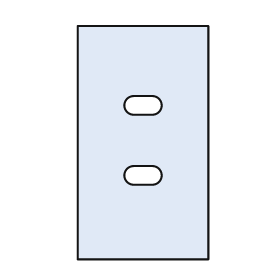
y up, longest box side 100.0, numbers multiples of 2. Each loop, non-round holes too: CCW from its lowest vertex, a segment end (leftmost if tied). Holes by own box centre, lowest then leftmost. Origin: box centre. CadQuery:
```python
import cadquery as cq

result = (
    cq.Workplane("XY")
    .moveTo(-28.0, -50.0)
    .lineTo(28.0, -50.0)
    .lineTo(28.0, 50.0)
    .lineTo(-28.0, 50.0)
    .close()
    .moveTo(-4.0, -18.0)
    .lineTo(4.0, -18.0)
    .threePointArc((8.0, -14.0), (4.0, -10.0))
    .lineTo(-4.0, -10.0)
    .threePointArc((-8.0, -14.0), (-4.0, -18.0))
    .close()
    .moveTo(-4.0, 12.0)
    .lineTo(4.0, 12.0)
    .threePointArc((8.0, 16.0), (4.0, 20.0))
    .lineTo(-4.0, 20.0)
    .threePointArc((-8.0, 16.0), (-4.0, 12.0))
    .close()
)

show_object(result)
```